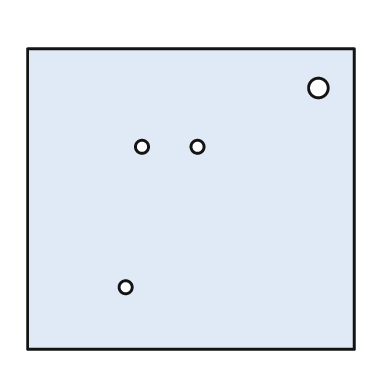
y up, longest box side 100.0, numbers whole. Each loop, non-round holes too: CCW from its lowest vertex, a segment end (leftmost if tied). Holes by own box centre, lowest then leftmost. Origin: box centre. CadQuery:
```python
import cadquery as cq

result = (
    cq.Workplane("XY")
    .moveTo(-50.0, -46.0)
    .lineTo(50.0, -46.0)
    .lineTo(50.0, 46.0)
    .lineTo(-50.0, 46.0)
    .close()
    .moveTo(-20.0, -27.0)
    .circle(2.0)
    .moveTo(-15.0, 16.0)
    .circle(2.0)
    .moveTo(2.0, 16.0)
    .circle(2.0)
    .moveTo(39.0, 34.0)
    .circle(3.0)
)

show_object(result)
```